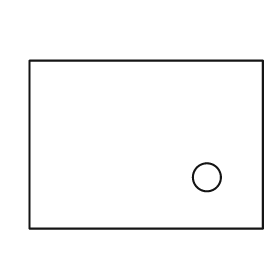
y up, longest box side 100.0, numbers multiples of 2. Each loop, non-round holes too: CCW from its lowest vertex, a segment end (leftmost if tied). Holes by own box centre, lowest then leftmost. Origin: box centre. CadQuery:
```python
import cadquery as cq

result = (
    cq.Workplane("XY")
    .moveTo(-50.0, -36.0)
    .lineTo(50.0, -36.0)
    .lineTo(50.0, 36.0)
    .lineTo(-50.0, 36.0)
    .close()
    .moveTo(26.0, -14.0)
    .circle(6.0)
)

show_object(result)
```